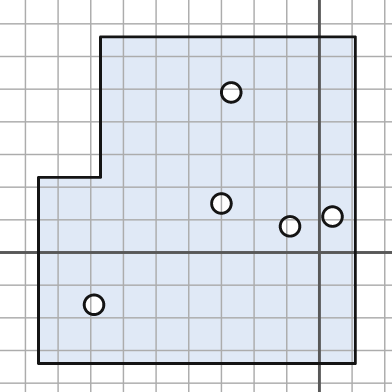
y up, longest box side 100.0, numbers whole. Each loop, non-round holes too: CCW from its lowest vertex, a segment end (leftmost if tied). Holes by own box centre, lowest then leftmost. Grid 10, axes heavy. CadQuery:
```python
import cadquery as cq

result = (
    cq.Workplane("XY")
    .moveTo(-86.0, -34.0)
    .lineTo(11.0, -34.0)
    .lineTo(11.0, 66.0)
    .lineTo(-67.0, 66.0)
    .lineTo(-67.0, 23.0)
    .lineTo(-86.0, 23.0)
    .close()
    .moveTo(-69.0, -16.0)
    .circle(3.0)
    .moveTo(-9.0, 8.0)
    .circle(3.0)
    .moveTo(4.0, 11.0)
    .circle(3.0)
    .moveTo(-30.0, 15.0)
    .circle(3.0)
    .moveTo(-27.0, 49.0)
    .circle(3.0)
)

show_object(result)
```